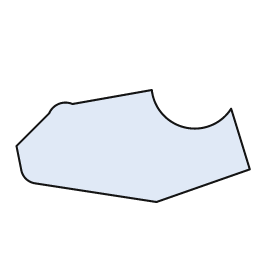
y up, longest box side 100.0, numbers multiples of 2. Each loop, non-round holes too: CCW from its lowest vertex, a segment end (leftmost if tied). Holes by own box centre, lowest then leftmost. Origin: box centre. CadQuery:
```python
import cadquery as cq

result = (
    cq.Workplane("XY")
    .moveTo(10.0, -24.0)
    .lineTo(50.0, -10.0)
    .lineTo(42.0, 16.0)
    .threePointArc((22.0, 8.0), (8.0, 24.0))
    .lineTo(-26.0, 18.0)
    .threePointArc((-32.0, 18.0), (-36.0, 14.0))
    .lineTo(-50.0, 0.0)
    .lineTo(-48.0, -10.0)
    .threePointArc((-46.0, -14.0), (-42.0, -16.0))
    .close()
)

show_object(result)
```